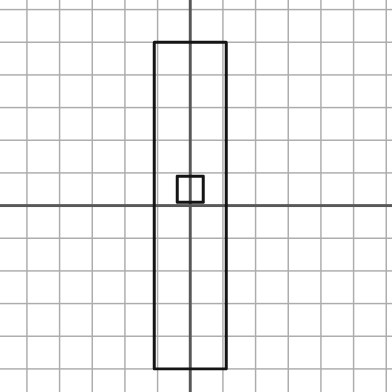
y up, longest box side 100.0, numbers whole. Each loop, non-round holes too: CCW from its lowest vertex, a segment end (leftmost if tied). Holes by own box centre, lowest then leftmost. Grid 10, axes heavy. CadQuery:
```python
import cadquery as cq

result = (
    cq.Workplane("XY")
    .moveTo(-11.0, -50.0)
    .lineTo(11.0, -50.0)
    .lineTo(11.0, 50.0)
    .lineTo(-11.0, 50.0)
    .close()
    .moveTo(-4.0, 1.0)
    .lineTo(4.0, 1.0)
    .lineTo(4.0, 9.0)
    .lineTo(-4.0, 9.0)
    .close()
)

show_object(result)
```